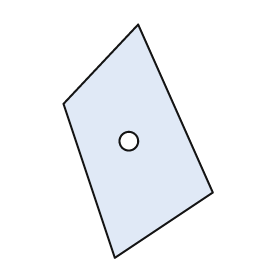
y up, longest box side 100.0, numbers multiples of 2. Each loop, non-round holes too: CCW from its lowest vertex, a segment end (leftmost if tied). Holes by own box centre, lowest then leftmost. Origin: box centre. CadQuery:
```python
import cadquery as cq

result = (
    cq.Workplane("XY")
    .moveTo(-10.0, -50.0)
    .lineTo(32.0, -22.0)
    .lineTo(0.0, 50.0)
    .lineTo(-32.0, 16.0)
    .close()
    .moveTo(-4.0, 0.0)
    .circle(4.0)
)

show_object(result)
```